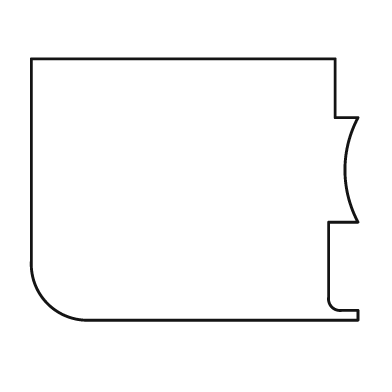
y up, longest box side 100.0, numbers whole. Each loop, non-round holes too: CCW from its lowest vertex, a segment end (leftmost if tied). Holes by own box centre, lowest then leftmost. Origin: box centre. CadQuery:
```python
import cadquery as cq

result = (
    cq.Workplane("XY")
    .moveTo(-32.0, -40.0)
    .lineTo(50.0, -40.0)
    .lineTo(50.0, -37.0)
    .lineTo(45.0, -37.0)
    .threePointArc((42.0, -36.0), (41.0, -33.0))
    .lineTo(41.0, -10.0)
    .lineTo(50.0, -10.0)
    .threePointArc((46.0, 6.0), (50.0, 22.0))
    .lineTo(43.0, 22.0)
    .lineTo(43.0, 40.0)
    .lineTo(-50.0, 40.0)
    .lineTo(-50.0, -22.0)
    .threePointArc((-45.0, -35.0), (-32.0, -40.0))
    .close()
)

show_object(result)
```